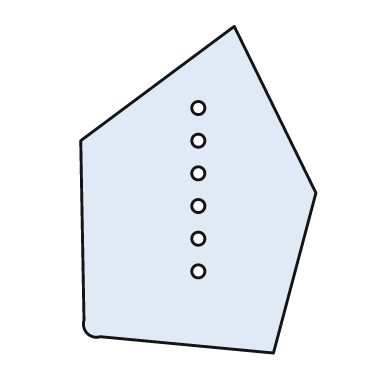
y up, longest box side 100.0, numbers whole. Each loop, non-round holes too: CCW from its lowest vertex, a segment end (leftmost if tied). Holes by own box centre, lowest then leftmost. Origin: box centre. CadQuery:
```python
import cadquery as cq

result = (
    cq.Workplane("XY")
    .moveTo(23.0, -50.0)
    .lineTo(36.0, -1.0)
    .lineTo(11.0, 50.0)
    .lineTo(-36.0, 15.0)
    .lineTo(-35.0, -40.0)
    .threePointArc((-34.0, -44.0), (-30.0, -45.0))
    .close()
    .moveTo(0.0, -25.0)
    .circle(2.0)
    .moveTo(0.0, -15.0)
    .circle(2.0)
    .moveTo(0.0, -5.0)
    .circle(2.0)
    .moveTo(0.0, 5.0)
    .circle(2.0)
    .moveTo(0.0, 15.0)
    .circle(2.0)
    .moveTo(0.0, 25.0)
    .circle(2.0)
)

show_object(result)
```